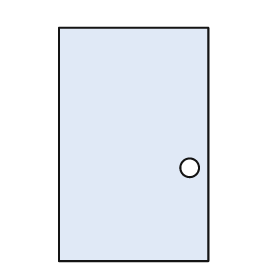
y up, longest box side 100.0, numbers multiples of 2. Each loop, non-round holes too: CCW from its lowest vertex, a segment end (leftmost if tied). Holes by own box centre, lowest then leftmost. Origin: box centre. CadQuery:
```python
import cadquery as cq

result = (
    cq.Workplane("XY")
    .moveTo(-32.0, -50.0)
    .lineTo(32.0, -50.0)
    .lineTo(32.0, 50.0)
    .lineTo(-32.0, 50.0)
    .close()
    .moveTo(24.0, -10.0)
    .circle(4.0)
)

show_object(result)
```